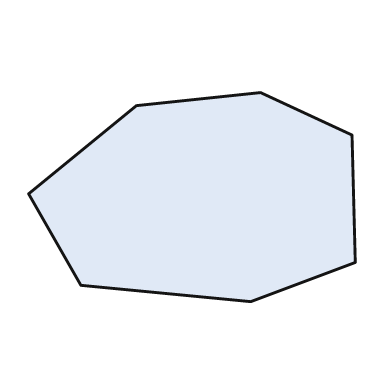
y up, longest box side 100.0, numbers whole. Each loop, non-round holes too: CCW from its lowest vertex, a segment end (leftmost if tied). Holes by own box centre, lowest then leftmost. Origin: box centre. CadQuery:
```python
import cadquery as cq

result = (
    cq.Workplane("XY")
    .moveTo(18.0, -32.0)
    .lineTo(50.0, -20.0)
    .lineTo(49.0, 19.0)
    .lineTo(21.0, 32.0)
    .lineTo(-17.0, 28.0)
    .lineTo(-50.0, 1.0)
    .lineTo(-34.0, -27.0)
    .close()
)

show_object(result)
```